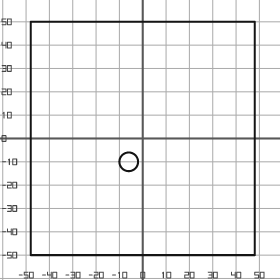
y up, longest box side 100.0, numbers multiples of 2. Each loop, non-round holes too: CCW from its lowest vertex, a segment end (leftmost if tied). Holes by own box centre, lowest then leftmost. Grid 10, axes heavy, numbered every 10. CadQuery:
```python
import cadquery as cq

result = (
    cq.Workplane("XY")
    .moveTo(-48.0, -50.0)
    .lineTo(48.0, -50.0)
    .lineTo(48.0, 50.0)
    .lineTo(-48.0, 50.0)
    .close()
    .moveTo(-6.0, -10.0)
    .circle(4.0)
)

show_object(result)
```